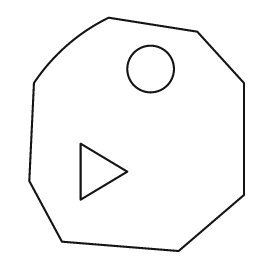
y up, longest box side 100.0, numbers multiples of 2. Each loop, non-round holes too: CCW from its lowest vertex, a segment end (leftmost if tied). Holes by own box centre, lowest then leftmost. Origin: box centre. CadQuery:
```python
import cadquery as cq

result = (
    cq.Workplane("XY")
    .moveTo(18.0, -50.0)
    .lineTo(46.0, -26.0)
    .lineTo(46.0, 22.0)
    .lineTo(26.0, 44.0)
    .lineTo(-12.0, 50.0)
    .threePointArc((-30.0, 38.0), (-44.0, 22.0))
    .lineTo(-46.0, -20.0)
    .lineTo(-32.0, -46.0)
    .close()
    .moveTo(-24.0, -28.0)
    .lineTo(-4.0, -16.0)
    .lineTo(-24.0, -4.0)
    .close()
    .moveTo(6.0, 28.0)
    .circle(10.0)
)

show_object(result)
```